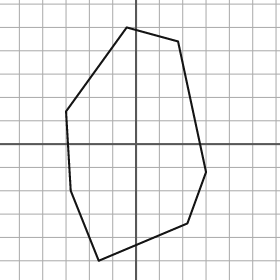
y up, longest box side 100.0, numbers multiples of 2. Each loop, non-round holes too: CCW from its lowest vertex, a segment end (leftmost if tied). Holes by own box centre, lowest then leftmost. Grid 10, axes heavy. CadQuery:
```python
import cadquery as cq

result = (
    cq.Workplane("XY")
    .moveTo(-16.0, -50.0)
    .lineTo(22.0, -34.0)
    .lineTo(30.0, -12.0)
    .lineTo(18.0, 44.0)
    .lineTo(-4.0, 50.0)
    .lineTo(-30.0, 14.0)
    .lineTo(-28.0, -20.0)
    .close()
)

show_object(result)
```